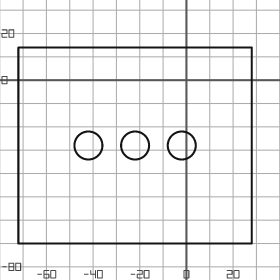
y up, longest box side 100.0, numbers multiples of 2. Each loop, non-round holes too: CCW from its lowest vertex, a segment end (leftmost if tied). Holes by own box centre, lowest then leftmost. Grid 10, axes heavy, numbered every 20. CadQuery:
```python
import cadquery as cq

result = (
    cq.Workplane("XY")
    .moveTo(-72.0, -70.0)
    .lineTo(28.0, -70.0)
    .lineTo(28.0, 14.0)
    .lineTo(-72.0, 14.0)
    .close()
    .moveTo(-42.0, -28.0)
    .circle(6.0)
    .moveTo(-22.0, -28.0)
    .circle(6.0)
    .moveTo(-2.0, -28.0)
    .circle(6.0)
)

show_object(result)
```